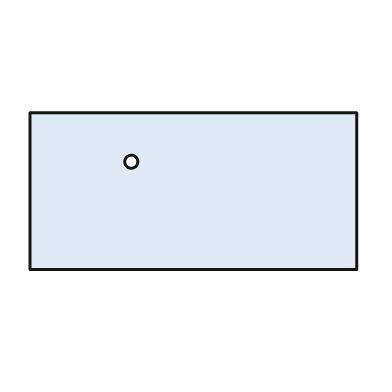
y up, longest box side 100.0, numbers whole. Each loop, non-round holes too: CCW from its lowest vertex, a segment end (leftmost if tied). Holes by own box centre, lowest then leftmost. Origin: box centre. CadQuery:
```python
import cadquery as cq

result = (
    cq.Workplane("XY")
    .moveTo(-50.0, -24.0)
    .lineTo(50.0, -24.0)
    .lineTo(50.0, 24.0)
    .lineTo(-50.0, 24.0)
    .close()
    .moveTo(-19.0, 9.0)
    .circle(2.0)
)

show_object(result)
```